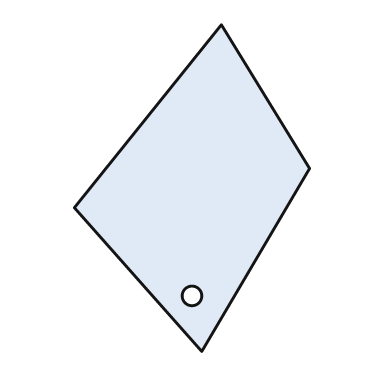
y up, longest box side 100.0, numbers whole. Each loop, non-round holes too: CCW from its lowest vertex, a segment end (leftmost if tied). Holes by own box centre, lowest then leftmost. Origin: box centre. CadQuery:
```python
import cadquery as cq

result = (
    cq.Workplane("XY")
    .moveTo(3.0, -50.0)
    .lineTo(36.0, 6.0)
    .lineTo(9.0, 50.0)
    .lineTo(-36.0, -6.0)
    .close()
    .moveTo(0.0, -33.0)
    .circle(3.0)
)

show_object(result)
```